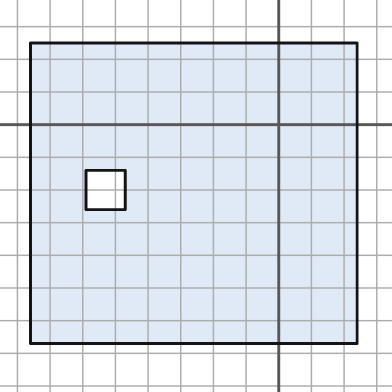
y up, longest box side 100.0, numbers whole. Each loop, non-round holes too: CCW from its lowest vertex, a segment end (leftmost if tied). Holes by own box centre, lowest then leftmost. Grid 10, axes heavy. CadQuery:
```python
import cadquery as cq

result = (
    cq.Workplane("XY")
    .moveTo(-76.0, -67.0)
    .lineTo(24.0, -67.0)
    .lineTo(24.0, 25.0)
    .lineTo(-76.0, 25.0)
    .close()
    .moveTo(-59.0, -26.0)
    .lineTo(-47.0, -26.0)
    .lineTo(-47.0, -14.0)
    .lineTo(-59.0, -14.0)
    .close()
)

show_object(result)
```